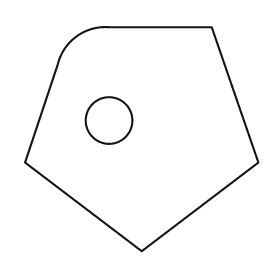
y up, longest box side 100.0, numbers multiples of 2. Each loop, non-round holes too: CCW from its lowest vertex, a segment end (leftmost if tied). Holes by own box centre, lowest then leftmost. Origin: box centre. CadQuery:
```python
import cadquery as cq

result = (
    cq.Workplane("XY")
    .moveTo(0.0, -48.0)
    .lineTo(50.0, -10.0)
    .lineTo(30.0, 48.0)
    .lineTo(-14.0, 48.0)
    .threePointArc((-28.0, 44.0), (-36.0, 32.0))
    .lineTo(-50.0, -10.0)
    .close()
    .moveTo(-14.0, 8.0)
    .circle(10.0)
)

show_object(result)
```